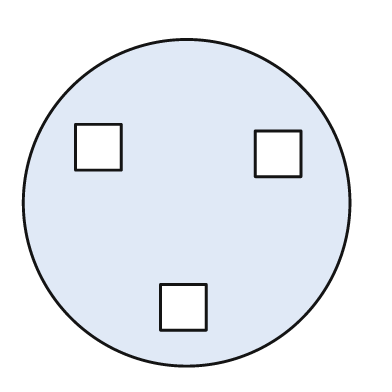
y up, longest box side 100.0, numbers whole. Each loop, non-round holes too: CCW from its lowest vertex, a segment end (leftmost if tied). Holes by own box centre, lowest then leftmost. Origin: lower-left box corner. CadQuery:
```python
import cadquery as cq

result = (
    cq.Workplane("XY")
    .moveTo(50.0, 50.0)
    .circle(50.0)
    .moveTo(42.0, 11.0)
    .lineTo(56.0, 11.0)
    .lineTo(56.0, 25.0)
    .lineTo(42.0, 25.0)
    .close()
    .moveTo(71.0, 58.0)
    .lineTo(85.0, 58.0)
    .lineTo(85.0, 72.0)
    .lineTo(71.0, 72.0)
    .close()
    .moveTo(16.0, 60.0)
    .lineTo(30.0, 60.0)
    .lineTo(30.0, 74.0)
    .lineTo(16.0, 74.0)
    .close()
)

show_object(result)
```